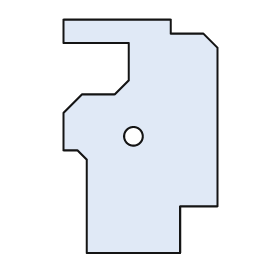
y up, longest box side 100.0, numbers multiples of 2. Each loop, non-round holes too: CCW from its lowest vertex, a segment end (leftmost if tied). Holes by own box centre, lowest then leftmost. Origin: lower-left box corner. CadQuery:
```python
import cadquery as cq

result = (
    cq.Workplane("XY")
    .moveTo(10.0, 0.0)
    .lineTo(50.0, 0.0)
    .lineTo(50.0, 20.0)
    .lineTo(66.0, 20.0)
    .lineTo(66.0, 88.0)
    .lineTo(60.0, 94.0)
    .lineTo(46.0, 94.0)
    .lineTo(46.0, 100.0)
    .lineTo(0.0, 100.0)
    .lineTo(0.0, 90.0)
    .lineTo(28.0, 90.0)
    .lineTo(28.0, 74.0)
    .lineTo(22.0, 68.0)
    .lineTo(8.0, 68.0)
    .lineTo(0.0, 60.0)
    .lineTo(0.0, 44.0)
    .lineTo(6.0, 44.0)
    .lineTo(10.0, 40.0)
    .close()
    .moveTo(30.0, 50.0)
    .circle(4.0)
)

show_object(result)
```